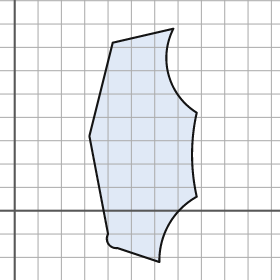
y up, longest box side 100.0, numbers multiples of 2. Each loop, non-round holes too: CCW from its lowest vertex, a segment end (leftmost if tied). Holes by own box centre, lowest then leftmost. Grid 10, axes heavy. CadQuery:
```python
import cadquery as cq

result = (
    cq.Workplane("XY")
    .moveTo(62.0, -22.0)
    .threePointArc((66.0, -6.0), (78.0, 6.0))
    .threePointArc((76.0, 24.0), (78.0, 42.0))
    .threePointArc((66.0, 58.0), (68.0, 78.0))
    .lineTo(42.0, 72.0)
    .lineTo(32.0, 32.0)
    .lineTo(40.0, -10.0)
    .threePointArc((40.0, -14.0), (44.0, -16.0))
    .close()
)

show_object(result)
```